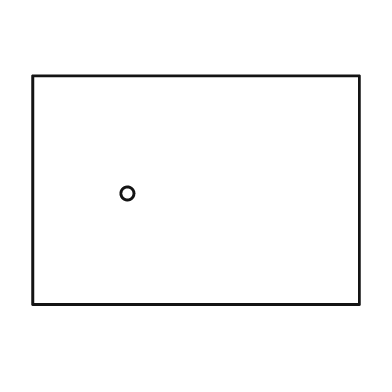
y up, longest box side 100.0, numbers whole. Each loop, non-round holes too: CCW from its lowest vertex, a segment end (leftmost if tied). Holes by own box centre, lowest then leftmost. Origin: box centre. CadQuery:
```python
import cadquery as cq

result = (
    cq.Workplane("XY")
    .moveTo(-50.0, -35.0)
    .lineTo(50.0, -35.0)
    .lineTo(50.0, 35.0)
    .lineTo(-50.0, 35.0)
    .close()
    .moveTo(-21.0, -1.0)
    .circle(2.0)
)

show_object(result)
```